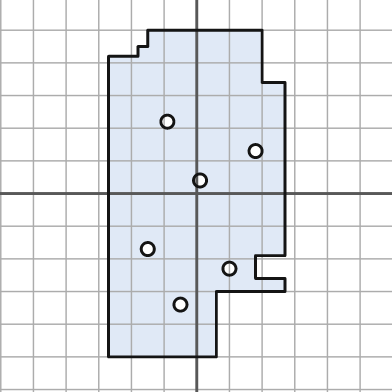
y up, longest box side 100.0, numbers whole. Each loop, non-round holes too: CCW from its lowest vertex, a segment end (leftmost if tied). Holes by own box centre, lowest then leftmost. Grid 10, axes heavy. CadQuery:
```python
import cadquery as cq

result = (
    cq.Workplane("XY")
    .moveTo(-27.0, -50.0)
    .lineTo(6.0, -50.0)
    .lineTo(6.0, -30.0)
    .lineTo(27.0, -30.0)
    .lineTo(27.0, -26.0)
    .lineTo(18.0, -26.0)
    .lineTo(18.0, -19.0)
    .lineTo(27.0, -19.0)
    .lineTo(27.0, 34.0)
    .lineTo(20.0, 34.0)
    .lineTo(20.0, 50.0)
    .lineTo(-15.0, 50.0)
    .lineTo(-15.0, 45.0)
    .lineTo(-18.0, 45.0)
    .lineTo(-18.0, 42.0)
    .lineTo(-27.0, 42.0)
    .close()
    .moveTo(-5.0, -34.0)
    .circle(2.0)
    .moveTo(10.0, -23.0)
    .circle(2.0)
    .moveTo(-15.0, -17.0)
    .circle(2.0)
    .moveTo(1.0, 4.0)
    .circle(2.0)
    .moveTo(18.0, 13.0)
    .circle(2.0)
    .moveTo(-9.0, 22.0)
    .circle(2.0)
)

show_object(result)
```